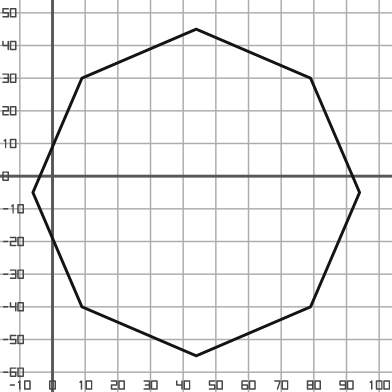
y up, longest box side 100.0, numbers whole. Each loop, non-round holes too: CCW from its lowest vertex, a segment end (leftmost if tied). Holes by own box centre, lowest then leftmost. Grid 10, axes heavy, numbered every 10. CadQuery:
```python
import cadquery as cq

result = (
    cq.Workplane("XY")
    .moveTo(44.0, -55.0)
    .lineTo(79.0, -40.0)
    .lineTo(94.0, -5.0)
    .lineTo(79.0, 30.0)
    .lineTo(44.0, 45.0)
    .lineTo(9.0, 30.0)
    .lineTo(-6.0, -5.0)
    .lineTo(9.0, -40.0)
    .close()
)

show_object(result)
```